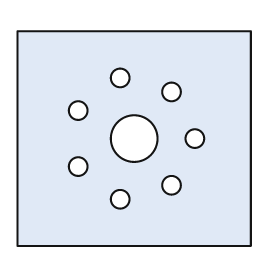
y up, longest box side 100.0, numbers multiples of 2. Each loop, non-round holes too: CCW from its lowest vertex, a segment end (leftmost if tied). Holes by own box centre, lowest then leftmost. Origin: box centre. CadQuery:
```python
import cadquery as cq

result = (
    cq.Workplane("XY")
    .moveTo(-50.0, -46.0)
    .lineTo(50.0, -46.0)
    .lineTo(50.0, 46.0)
    .lineTo(-50.0, 46.0)
    .close()
    .moveTo(-6.0, -26.0)
    .circle(4.0)
    .moveTo(16.0, -20.0)
    .circle(4.0)
    .moveTo(-24.0, -12.0)
    .circle(4.0)
    .moveTo(0.0, 0.0)
    .circle(10.0)
    .moveTo(26.0, 0.0)
    .circle(4.0)
    .moveTo(-24.0, 12.0)
    .circle(4.0)
    .moveTo(16.0, 20.0)
    .circle(4.0)
    .moveTo(-6.0, 26.0)
    .circle(4.0)
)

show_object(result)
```